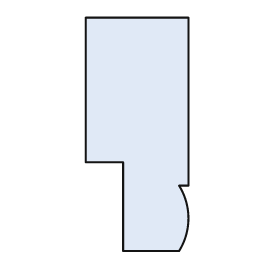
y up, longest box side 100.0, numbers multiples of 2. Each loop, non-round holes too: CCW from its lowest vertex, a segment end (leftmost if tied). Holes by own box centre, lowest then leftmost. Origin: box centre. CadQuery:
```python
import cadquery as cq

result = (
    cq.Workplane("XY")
    .moveTo(-6.0, -50.0)
    .lineTo(18.0, -50.0)
    .threePointArc((22.0, -36.0), (18.0, -22.0))
    .lineTo(22.0, -22.0)
    .lineTo(22.0, 50.0)
    .lineTo(-22.0, 50.0)
    .lineTo(-22.0, -12.0)
    .lineTo(-6.0, -12.0)
    .close()
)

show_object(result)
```